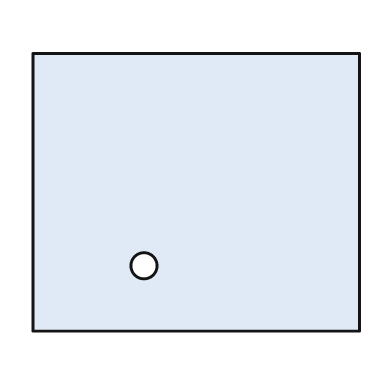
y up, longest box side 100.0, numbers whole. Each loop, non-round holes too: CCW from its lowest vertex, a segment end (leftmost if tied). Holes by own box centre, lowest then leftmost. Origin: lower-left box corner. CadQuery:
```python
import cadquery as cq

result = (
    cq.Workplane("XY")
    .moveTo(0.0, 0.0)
    .lineTo(100.0, 0.0)
    .lineTo(100.0, 85.0)
    .lineTo(0.0, 85.0)
    .close()
    .moveTo(34.0, 20.0)
    .circle(4.0)
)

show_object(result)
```